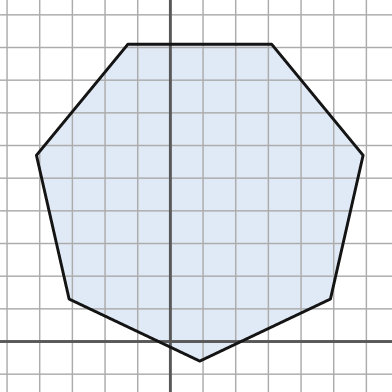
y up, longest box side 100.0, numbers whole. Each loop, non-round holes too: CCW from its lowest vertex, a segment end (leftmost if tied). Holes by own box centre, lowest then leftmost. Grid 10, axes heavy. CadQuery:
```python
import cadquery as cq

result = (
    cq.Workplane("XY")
    .moveTo(9.0, -6.0)
    .lineTo(49.0, 13.0)
    .lineTo(59.0, 57.0)
    .lineTo(31.0, 91.0)
    .lineTo(-13.0, 91.0)
    .lineTo(-41.0, 57.0)
    .lineTo(-31.0, 13.0)
    .close()
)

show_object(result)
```